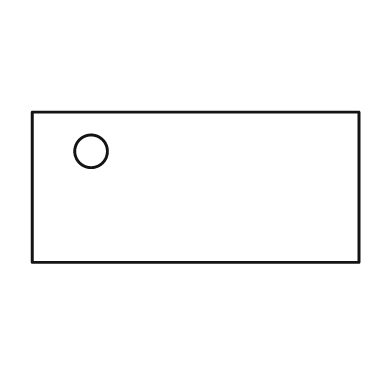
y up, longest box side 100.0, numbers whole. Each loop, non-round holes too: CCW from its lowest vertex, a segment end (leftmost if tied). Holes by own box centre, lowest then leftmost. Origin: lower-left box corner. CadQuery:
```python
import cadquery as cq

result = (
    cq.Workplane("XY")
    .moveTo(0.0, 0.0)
    .lineTo(100.0, 0.0)
    .lineTo(100.0, 46.0)
    .lineTo(0.0, 46.0)
    .close()
    .moveTo(18.0, 34.0)
    .circle(5.0)
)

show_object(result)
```